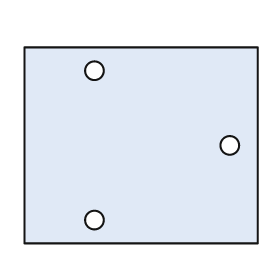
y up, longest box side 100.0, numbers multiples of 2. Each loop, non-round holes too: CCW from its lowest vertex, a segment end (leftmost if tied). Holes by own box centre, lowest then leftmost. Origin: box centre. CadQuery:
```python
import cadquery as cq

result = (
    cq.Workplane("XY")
    .moveTo(-50.0, -42.0)
    .lineTo(50.0, -42.0)
    .lineTo(50.0, 42.0)
    .lineTo(-50.0, 42.0)
    .close()
    .moveTo(-20.0, -32.0)
    .circle(4.0)
    .moveTo(38.0, 0.0)
    .circle(4.0)
    .moveTo(-20.0, 32.0)
    .circle(4.0)
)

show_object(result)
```